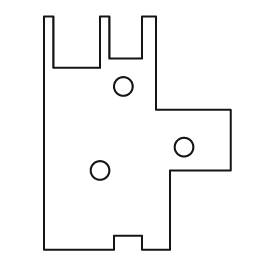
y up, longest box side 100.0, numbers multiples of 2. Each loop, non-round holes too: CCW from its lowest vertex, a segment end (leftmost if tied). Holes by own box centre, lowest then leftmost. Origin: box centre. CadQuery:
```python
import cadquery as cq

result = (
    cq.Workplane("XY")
    .moveTo(-40.0, -50.0)
    .lineTo(-10.0, -50.0)
    .lineTo(-10.0, -44.0)
    .lineTo(2.0, -44.0)
    .lineTo(2.0, -50.0)
    .lineTo(14.0, -50.0)
    .lineTo(14.0, -16.0)
    .lineTo(40.0, -16.0)
    .lineTo(40.0, 10.0)
    .lineTo(8.0, 10.0)
    .lineTo(8.0, 50.0)
    .lineTo(2.0, 50.0)
    .lineTo(2.0, 32.0)
    .lineTo(-12.0, 32.0)
    .lineTo(-12.0, 50.0)
    .lineTo(-16.0, 50.0)
    .lineTo(-16.0, 28.0)
    .lineTo(-36.0, 28.0)
    .lineTo(-36.0, 50.0)
    .lineTo(-40.0, 50.0)
    .close()
    .moveTo(-16.0, -16.0)
    .circle(4.0)
    .moveTo(20.0, -6.0)
    .circle(4.0)
    .moveTo(-6.0, 20.0)
    .circle(4.0)
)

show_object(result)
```